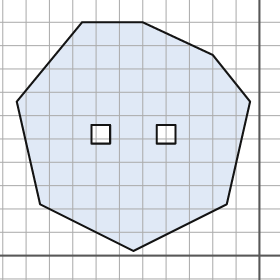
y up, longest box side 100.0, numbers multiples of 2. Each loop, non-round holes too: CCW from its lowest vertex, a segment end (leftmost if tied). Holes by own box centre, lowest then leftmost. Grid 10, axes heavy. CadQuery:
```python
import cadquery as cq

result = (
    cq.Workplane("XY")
    .moveTo(-54.0, 2.0)
    .lineTo(-14.0, 22.0)
    .lineTo(-4.0, 66.0)
    .lineTo(-20.0, 86.0)
    .lineTo(-50.0, 100.0)
    .lineTo(-76.0, 100.0)
    .lineTo(-104.0, 66.0)
    .lineTo(-94.0, 22.0)
    .close()
    .moveTo(-72.0, 48.0)
    .lineTo(-64.0, 48.0)
    .lineTo(-64.0, 56.0)
    .lineTo(-72.0, 56.0)
    .close()
    .moveTo(-44.0, 48.0)
    .lineTo(-36.0, 48.0)
    .lineTo(-36.0, 56.0)
    .lineTo(-44.0, 56.0)
    .close()
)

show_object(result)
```